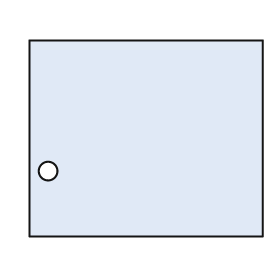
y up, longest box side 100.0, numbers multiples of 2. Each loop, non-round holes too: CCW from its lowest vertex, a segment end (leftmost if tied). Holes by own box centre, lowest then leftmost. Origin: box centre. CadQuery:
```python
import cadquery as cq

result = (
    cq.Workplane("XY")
    .moveTo(-50.0, -42.0)
    .lineTo(50.0, -42.0)
    .lineTo(50.0, 42.0)
    .lineTo(-50.0, 42.0)
    .close()
    .moveTo(-42.0, -14.0)
    .circle(4.0)
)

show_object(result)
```